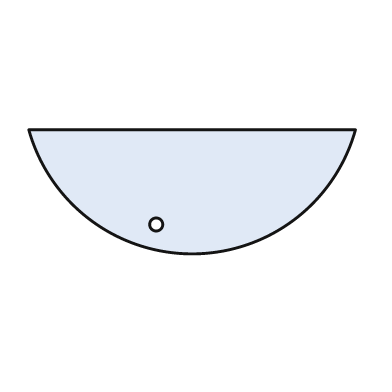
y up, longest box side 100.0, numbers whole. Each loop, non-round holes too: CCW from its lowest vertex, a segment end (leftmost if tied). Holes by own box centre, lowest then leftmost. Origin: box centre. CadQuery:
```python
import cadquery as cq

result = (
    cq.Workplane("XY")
    .moveTo(-50.0, 19.0)
    .threePointArc((0.0, -19.0), (50.0, 19.0))
    .close()
    .moveTo(-11.0, -10.0)
    .circle(2.0)
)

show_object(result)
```